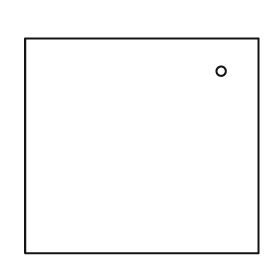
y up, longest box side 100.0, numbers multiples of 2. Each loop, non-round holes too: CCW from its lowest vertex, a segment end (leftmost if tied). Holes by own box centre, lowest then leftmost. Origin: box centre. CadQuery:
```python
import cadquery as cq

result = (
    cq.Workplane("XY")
    .moveTo(-50.0, -46.0)
    .lineTo(50.0, -46.0)
    .lineTo(50.0, 46.0)
    .lineTo(-50.0, 46.0)
    .close()
    .moveTo(34.0, 32.0)
    .circle(2.0)
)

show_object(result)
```